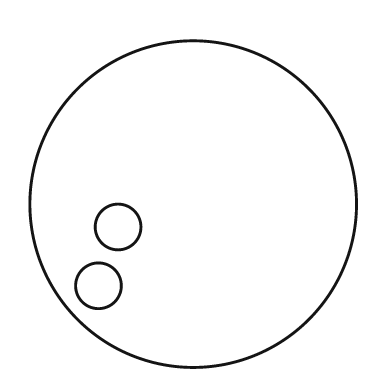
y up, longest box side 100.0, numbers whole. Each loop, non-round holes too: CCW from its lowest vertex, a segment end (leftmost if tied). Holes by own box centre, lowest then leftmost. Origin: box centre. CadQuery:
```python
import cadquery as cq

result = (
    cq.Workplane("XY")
    .moveTo(0.0, 0.0)
    .circle(50.0)
    .moveTo(-29.0, -25.0)
    .circle(7.0)
    .moveTo(-23.0, -7.0)
    .circle(7.0)
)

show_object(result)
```